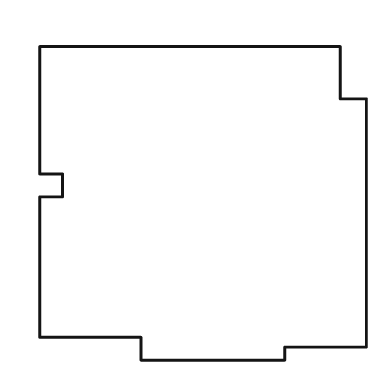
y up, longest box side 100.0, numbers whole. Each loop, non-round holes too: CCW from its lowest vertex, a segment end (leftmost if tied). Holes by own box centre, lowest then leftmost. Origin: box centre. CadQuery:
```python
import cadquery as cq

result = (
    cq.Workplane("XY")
    .moveTo(-19.0, -48.0)
    .lineTo(25.0, -48.0)
    .lineTo(25.0, -44.0)
    .lineTo(50.0, -44.0)
    .lineTo(50.0, 32.0)
    .lineTo(42.0, 32.0)
    .lineTo(42.0, 48.0)
    .lineTo(-50.0, 48.0)
    .lineTo(-50.0, 9.0)
    .lineTo(-43.0, 9.0)
    .lineTo(-43.0, 2.0)
    .lineTo(-50.0, 2.0)
    .lineTo(-50.0, -41.0)
    .lineTo(-19.0, -41.0)
    .close()
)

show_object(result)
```